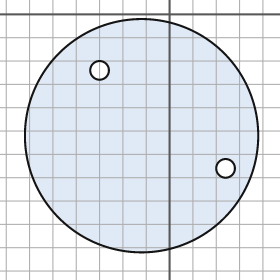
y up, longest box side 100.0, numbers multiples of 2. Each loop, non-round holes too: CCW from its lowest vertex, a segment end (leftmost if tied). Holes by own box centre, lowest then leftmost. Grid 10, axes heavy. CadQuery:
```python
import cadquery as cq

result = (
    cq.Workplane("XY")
    .moveTo(-12.0, -52.0)
    .circle(50.0)
    .moveTo(24.0, -66.0)
    .circle(4.0)
    .moveTo(-30.0, -24.0)
    .circle(4.0)
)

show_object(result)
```